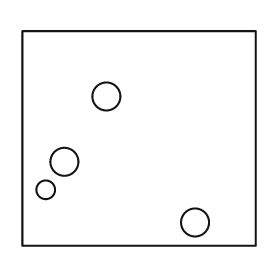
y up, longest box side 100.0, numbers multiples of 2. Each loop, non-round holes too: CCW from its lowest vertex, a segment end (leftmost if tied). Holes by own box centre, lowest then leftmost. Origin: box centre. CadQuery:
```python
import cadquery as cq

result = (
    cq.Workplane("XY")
    .moveTo(-50.0, -46.0)
    .lineTo(50.0, -46.0)
    .lineTo(50.0, 46.0)
    .lineTo(-50.0, 46.0)
    .close()
    .moveTo(24.0, -36.0)
    .circle(6.0)
    .moveTo(-40.0, -22.0)
    .circle(4.0)
    .moveTo(-32.0, -10.0)
    .circle(6.0)
    .moveTo(-14.0, 18.0)
    .circle(6.0)
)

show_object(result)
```